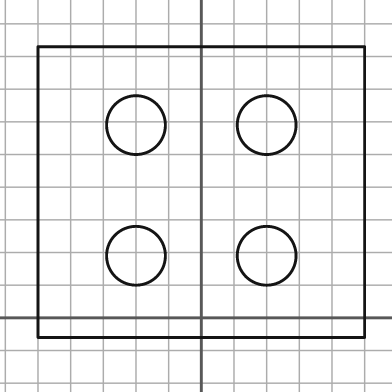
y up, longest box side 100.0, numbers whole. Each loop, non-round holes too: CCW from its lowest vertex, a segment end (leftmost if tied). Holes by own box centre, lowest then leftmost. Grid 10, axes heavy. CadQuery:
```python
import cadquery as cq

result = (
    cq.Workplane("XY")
    .moveTo(-50.0, -6.0)
    .lineTo(50.0, -6.0)
    .lineTo(50.0, 83.0)
    .lineTo(-50.0, 83.0)
    .close()
    .moveTo(-20.0, 19.0)
    .circle(9.0)
    .moveTo(20.0, 19.0)
    .circle(9.0)
    .moveTo(-20.0, 59.0)
    .circle(9.0)
    .moveTo(20.0, 59.0)
    .circle(9.0)
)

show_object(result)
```